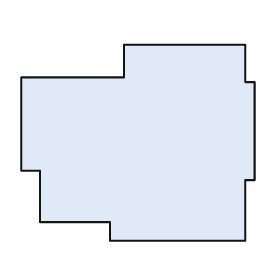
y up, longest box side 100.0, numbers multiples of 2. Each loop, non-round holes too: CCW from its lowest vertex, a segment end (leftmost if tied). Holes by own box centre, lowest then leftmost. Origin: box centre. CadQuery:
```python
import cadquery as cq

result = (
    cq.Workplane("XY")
    .moveTo(-12.0, -42.0)
    .lineTo(46.0, -42.0)
    .lineTo(46.0, -16.0)
    .lineTo(50.0, -16.0)
    .lineTo(50.0, 26.0)
    .lineTo(46.0, 26.0)
    .lineTo(46.0, 42.0)
    .lineTo(-6.0, 42.0)
    .lineTo(-6.0, 28.0)
    .lineTo(-50.0, 28.0)
    .lineTo(-50.0, -12.0)
    .lineTo(-42.0, -12.0)
    .lineTo(-42.0, -34.0)
    .lineTo(-12.0, -34.0)
    .close()
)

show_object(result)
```